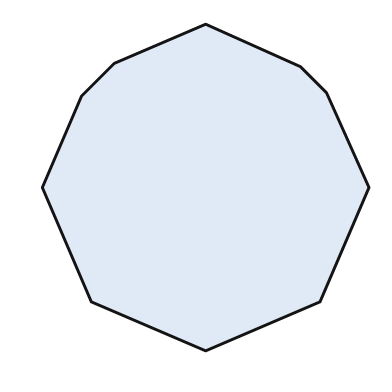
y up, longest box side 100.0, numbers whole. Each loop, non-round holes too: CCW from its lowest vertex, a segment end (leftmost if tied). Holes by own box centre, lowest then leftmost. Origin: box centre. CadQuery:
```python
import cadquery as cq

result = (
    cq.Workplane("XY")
    .moveTo(0.0, -50.0)
    .lineTo(35.0, -35.0)
    .lineTo(50.0, 0.0)
    .lineTo(37.0, 29.0)
    .lineTo(29.0, 37.0)
    .lineTo(0.0, 50.0)
    .lineTo(-28.0, 38.0)
    .lineTo(-38.0, 28.0)
    .lineTo(-50.0, 0.0)
    .lineTo(-35.0, -35.0)
    .close()
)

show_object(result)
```